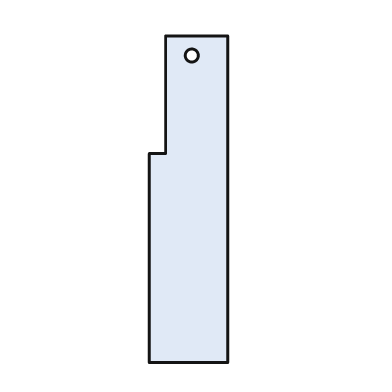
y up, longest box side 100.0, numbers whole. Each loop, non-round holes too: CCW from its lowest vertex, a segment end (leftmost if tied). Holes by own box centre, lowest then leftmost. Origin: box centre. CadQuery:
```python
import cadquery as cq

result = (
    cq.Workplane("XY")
    .moveTo(-12.0, -50.0)
    .lineTo(12.0, -50.0)
    .lineTo(12.0, 50.0)
    .lineTo(-7.0, 50.0)
    .lineTo(-7.0, 14.0)
    .lineTo(-12.0, 14.0)
    .close()
    .moveTo(1.0, 44.0)
    .circle(2.0)
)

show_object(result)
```